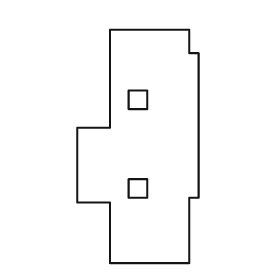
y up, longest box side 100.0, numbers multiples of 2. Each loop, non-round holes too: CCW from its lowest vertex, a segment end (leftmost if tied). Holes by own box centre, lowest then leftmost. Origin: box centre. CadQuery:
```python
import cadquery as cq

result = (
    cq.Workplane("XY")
    .moveTo(-12.0, -50.0)
    .lineTo(22.0, -50.0)
    .lineTo(22.0, -22.0)
    .lineTo(26.0, -22.0)
    .lineTo(26.0, 40.0)
    .lineTo(22.0, 40.0)
    .lineTo(22.0, 50.0)
    .lineTo(-12.0, 50.0)
    .lineTo(-12.0, 8.0)
    .lineTo(-26.0, 8.0)
    .lineTo(-26.0, -24.0)
    .lineTo(-12.0, -24.0)
    .close()
    .moveTo(-4.0, -22.0)
    .lineTo(4.0, -22.0)
    .lineTo(4.0, -14.0)
    .lineTo(-4.0, -14.0)
    .close()
    .moveTo(-4.0, 16.0)
    .lineTo(4.0, 16.0)
    .lineTo(4.0, 24.0)
    .lineTo(-4.0, 24.0)
    .close()
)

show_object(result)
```